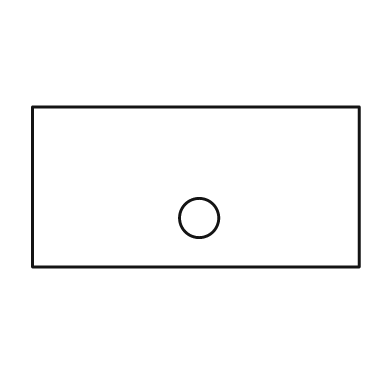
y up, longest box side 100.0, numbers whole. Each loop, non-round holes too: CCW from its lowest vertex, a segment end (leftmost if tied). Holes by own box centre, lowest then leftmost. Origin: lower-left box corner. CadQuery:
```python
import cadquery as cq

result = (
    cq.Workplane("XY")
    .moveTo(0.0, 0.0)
    .lineTo(100.0, 0.0)
    .lineTo(100.0, 49.0)
    .lineTo(0.0, 49.0)
    .close()
    .moveTo(51.0, 15.0)
    .circle(6.0)
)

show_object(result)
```